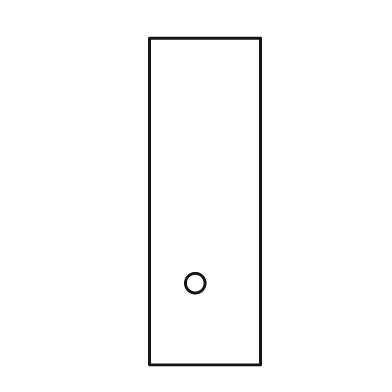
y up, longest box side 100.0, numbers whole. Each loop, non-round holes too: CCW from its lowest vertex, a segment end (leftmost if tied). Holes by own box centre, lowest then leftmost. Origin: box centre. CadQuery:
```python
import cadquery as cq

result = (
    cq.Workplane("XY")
    .moveTo(-17.0, -50.0)
    .lineTo(17.0, -50.0)
    .lineTo(17.0, 50.0)
    .lineTo(-17.0, 50.0)
    .close()
    .moveTo(-3.0, -25.0)
    .circle(3.0)
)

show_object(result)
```